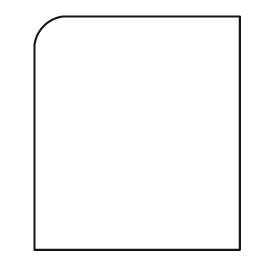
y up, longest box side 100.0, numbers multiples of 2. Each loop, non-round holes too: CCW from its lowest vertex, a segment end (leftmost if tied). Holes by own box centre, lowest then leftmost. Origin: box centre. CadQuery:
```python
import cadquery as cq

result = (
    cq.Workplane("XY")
    .moveTo(-44.0, -50.0)
    .lineTo(44.0, -50.0)
    .lineTo(44.0, 50.0)
    .lineTo(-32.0, 50.0)
    .threePointArc((-40.0, 46.0), (-44.0, 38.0))
    .close()
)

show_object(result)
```